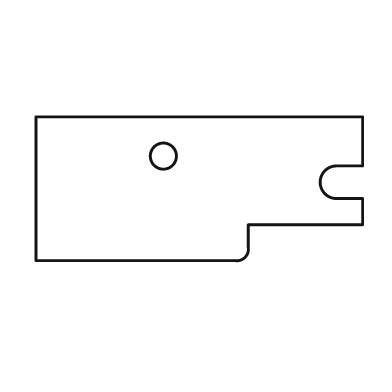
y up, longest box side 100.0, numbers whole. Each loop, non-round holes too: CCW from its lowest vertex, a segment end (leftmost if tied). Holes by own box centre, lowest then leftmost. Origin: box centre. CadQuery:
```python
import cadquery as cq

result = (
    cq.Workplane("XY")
    .moveTo(-50.0, -22.0)
    .lineTo(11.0, -22.0)
    .threePointArc((14.0, -21.0), (15.0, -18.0))
    .lineTo(15.0, -11.0)
    .lineTo(50.0, -11.0)
    .lineTo(50.0, -3.0)
    .lineTo(42.0, -3.0)
    .threePointArc((37.0, 2.0), (42.0, 7.0))
    .lineTo(50.0, 7.0)
    .lineTo(50.0, 22.0)
    .lineTo(-50.0, 22.0)
    .close()
    .moveTo(-11.0, 10.0)
    .circle(4.0)
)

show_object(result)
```